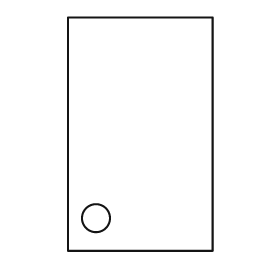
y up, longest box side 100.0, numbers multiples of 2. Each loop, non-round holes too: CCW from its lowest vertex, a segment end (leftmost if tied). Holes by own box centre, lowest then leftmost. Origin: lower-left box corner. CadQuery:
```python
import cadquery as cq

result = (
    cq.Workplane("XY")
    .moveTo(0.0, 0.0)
    .lineTo(62.0, 0.0)
    .lineTo(62.0, 100.0)
    .lineTo(0.0, 100.0)
    .close()
    .moveTo(12.0, 14.0)
    .circle(6.0)
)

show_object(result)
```